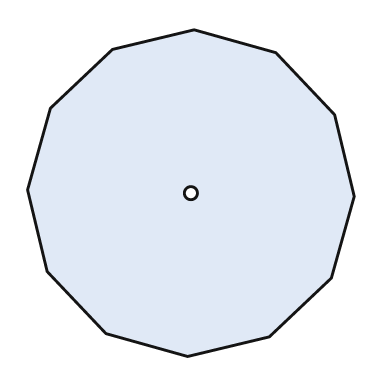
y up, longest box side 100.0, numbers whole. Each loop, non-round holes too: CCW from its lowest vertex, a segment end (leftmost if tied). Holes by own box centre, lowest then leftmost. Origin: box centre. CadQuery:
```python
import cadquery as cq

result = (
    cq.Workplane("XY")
    .moveTo(-1.0, -50.0)
    .lineTo(24.0, -44.0)
    .lineTo(43.0, -26.0)
    .lineTo(50.0, -1.0)
    .lineTo(44.0, 24.0)
    .lineTo(26.0, 43.0)
    .lineTo(1.0, 50.0)
    .lineTo(-24.0, 44.0)
    .lineTo(-43.0, 26.0)
    .lineTo(-50.0, 1.0)
    .lineTo(-44.0, -24.0)
    .lineTo(-26.0, -43.0)
    .close()
    .moveTo(0.0, 0.0)
    .circle(2.0)
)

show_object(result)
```